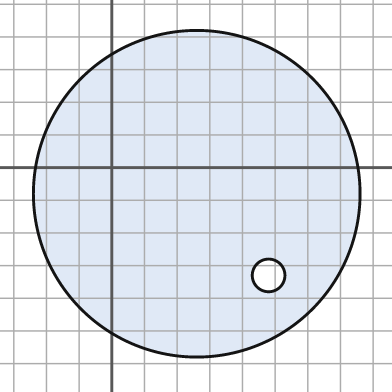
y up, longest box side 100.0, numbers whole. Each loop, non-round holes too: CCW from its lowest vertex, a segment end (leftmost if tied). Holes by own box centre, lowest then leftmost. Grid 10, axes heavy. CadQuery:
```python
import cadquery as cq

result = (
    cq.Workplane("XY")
    .moveTo(26.0, -8.0)
    .circle(50.0)
    .moveTo(48.0, -33.0)
    .circle(5.0)
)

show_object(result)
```